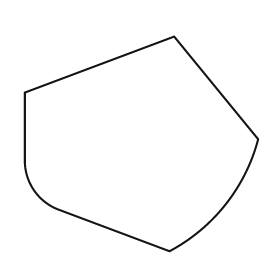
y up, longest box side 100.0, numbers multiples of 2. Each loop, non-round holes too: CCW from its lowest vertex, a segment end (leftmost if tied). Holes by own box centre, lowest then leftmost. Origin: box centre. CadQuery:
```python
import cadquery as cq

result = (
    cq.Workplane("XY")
    .moveTo(12.0, -46.0)
    .threePointArc((36.0, -26.0), (50.0, 2.0))
    .lineTo(14.0, 46.0)
    .lineTo(-50.0, 22.0)
    .lineTo(-50.0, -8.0)
    .threePointArc((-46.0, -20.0), (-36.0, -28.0))
    .close()
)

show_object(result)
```